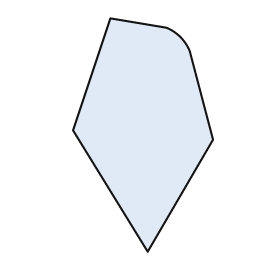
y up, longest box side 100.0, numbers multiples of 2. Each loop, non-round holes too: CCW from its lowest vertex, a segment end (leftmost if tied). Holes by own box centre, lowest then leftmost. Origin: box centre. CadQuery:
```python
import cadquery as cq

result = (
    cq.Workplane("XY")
    .moveTo(2.0, -50.0)
    .lineTo(30.0, -2.0)
    .lineTo(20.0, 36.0)
    .threePointArc((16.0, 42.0), (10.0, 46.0))
    .lineTo(-14.0, 50.0)
    .lineTo(-30.0, 2.0)
    .close()
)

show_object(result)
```